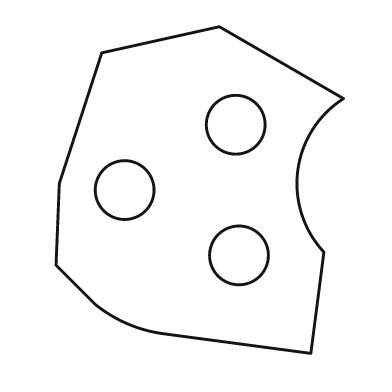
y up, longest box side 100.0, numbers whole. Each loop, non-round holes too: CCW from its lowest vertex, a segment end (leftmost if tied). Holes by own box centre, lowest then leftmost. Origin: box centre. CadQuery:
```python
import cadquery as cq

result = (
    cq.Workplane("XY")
    .moveTo(34.0, -50.0)
    .lineTo(38.0, -19.0)
    .threePointArc((30.0, 6.0), (44.0, 28.0))
    .lineTo(6.0, 50.0)
    .lineTo(-30.0, 42.0)
    .lineTo(-43.0, 2.0)
    .lineTo(-44.0, -23.0)
    .lineTo(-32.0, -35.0)
    .threePointArc((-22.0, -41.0), (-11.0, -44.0))
    .close()
    .moveTo(12.0, -20.0)
    .circle(9.0)
    .moveTo(-23.0, 0.0)
    .circle(9.0)
    .moveTo(11.0, 20.0)
    .circle(9.0)
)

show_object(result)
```